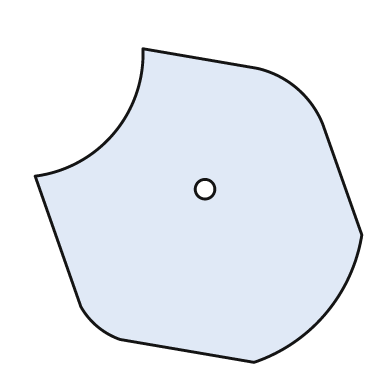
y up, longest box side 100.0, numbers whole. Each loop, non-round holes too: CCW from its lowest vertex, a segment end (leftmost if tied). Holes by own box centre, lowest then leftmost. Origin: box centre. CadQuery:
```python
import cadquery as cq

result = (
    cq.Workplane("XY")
    .moveTo(17.0, -48.0)
    .threePointArc((39.0, -33.0), (50.0, -9.0))
    .lineTo(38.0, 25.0)
    .threePointArc((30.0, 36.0), (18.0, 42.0))
    .lineTo(-17.0, 48.0)
    .threePointArc((-26.0, 22.0), (-50.0, 9.0))
    .lineTo(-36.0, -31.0)
    .threePointArc((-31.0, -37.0), (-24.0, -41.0))
    .close()
    .moveTo(2.0, 5.0)
    .circle(3.0)
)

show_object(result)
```